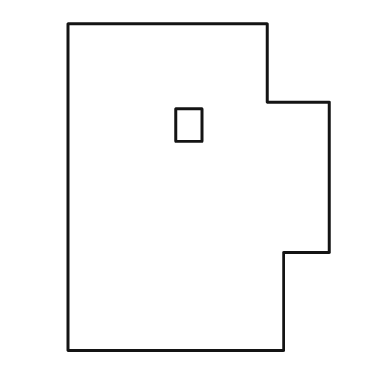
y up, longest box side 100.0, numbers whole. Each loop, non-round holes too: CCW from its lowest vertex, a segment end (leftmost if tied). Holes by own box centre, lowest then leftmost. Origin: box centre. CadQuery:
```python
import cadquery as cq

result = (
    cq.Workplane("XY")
    .moveTo(-40.0, -50.0)
    .lineTo(26.0, -50.0)
    .lineTo(26.0, -20.0)
    .lineTo(40.0, -20.0)
    .lineTo(40.0, 26.0)
    .lineTo(21.0, 26.0)
    .lineTo(21.0, 50.0)
    .lineTo(-40.0, 50.0)
    .close()
    .moveTo(-7.0, 14.0)
    .lineTo(1.0, 14.0)
    .lineTo(1.0, 24.0)
    .lineTo(-7.0, 24.0)
    .close()
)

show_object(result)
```